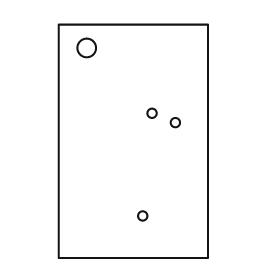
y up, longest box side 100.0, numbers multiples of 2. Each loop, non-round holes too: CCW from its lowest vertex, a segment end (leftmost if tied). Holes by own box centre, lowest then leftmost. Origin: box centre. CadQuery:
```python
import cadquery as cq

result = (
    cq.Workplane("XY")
    .moveTo(-32.0, -50.0)
    .lineTo(32.0, -50.0)
    .lineTo(32.0, 50.0)
    .lineTo(-32.0, 50.0)
    .close()
    .moveTo(4.0, -32.0)
    .circle(2.0)
    .moveTo(18.0, 8.0)
    .circle(2.0)
    .moveTo(8.0, 12.0)
    .circle(2.0)
    .moveTo(-20.0, 40.0)
    .circle(4.0)
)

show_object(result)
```